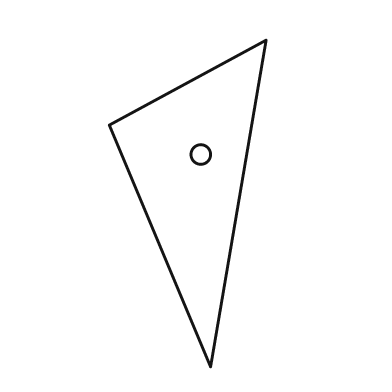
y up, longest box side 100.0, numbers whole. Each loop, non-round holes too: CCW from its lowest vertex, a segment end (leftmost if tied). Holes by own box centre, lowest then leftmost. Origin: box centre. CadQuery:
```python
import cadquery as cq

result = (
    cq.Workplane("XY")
    .moveTo(7.0, -50.0)
    .lineTo(24.0, 50.0)
    .lineTo(-24.0, 24.0)
    .close()
    .moveTo(4.0, 15.0)
    .circle(3.0)
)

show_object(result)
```